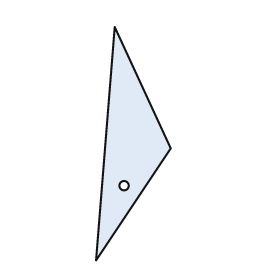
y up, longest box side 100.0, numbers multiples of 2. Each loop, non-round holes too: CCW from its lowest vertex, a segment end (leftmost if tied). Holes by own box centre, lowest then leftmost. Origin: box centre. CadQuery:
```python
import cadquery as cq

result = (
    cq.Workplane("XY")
    .moveTo(-16.0, -50.0)
    .lineTo(16.0, -2.0)
    .lineTo(-8.0, 50.0)
    .close()
    .moveTo(-4.0, -18.0)
    .circle(2.0)
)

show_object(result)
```